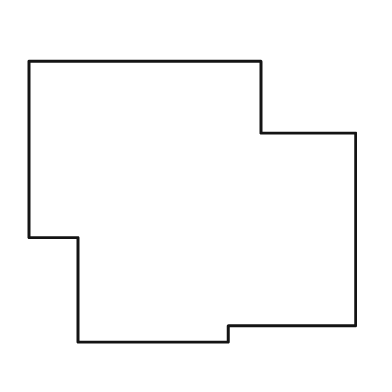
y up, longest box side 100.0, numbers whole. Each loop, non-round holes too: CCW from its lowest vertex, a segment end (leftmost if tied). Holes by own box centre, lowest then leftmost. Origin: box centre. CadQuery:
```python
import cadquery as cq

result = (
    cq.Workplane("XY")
    .moveTo(-35.0, -43.0)
    .lineTo(11.0, -43.0)
    .lineTo(11.0, -38.0)
    .lineTo(50.0, -38.0)
    .lineTo(50.0, 21.0)
    .lineTo(21.0, 21.0)
    .lineTo(21.0, 43.0)
    .lineTo(-50.0, 43.0)
    .lineTo(-50.0, -11.0)
    .lineTo(-35.0, -11.0)
    .close()
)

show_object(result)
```